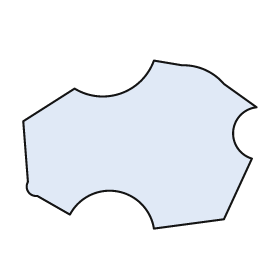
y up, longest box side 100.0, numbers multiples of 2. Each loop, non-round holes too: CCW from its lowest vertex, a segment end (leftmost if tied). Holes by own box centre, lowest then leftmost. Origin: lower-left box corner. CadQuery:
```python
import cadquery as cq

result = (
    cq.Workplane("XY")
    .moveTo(56.0, 0.0)
    .lineTo(86.0, 4.0)
    .lineTo(98.0, 30.0)
    .threePointArc((90.0, 42.0), (100.0, 52.0))
    .lineTo(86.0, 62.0)
    .threePointArc((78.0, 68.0), (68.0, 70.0))
    .lineTo(56.0, 72.0)
    .threePointArc((42.0, 58.0), (22.0, 60.0))
    .lineTo(0.0, 46.0)
    .lineTo(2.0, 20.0)
    .threePointArc((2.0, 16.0), (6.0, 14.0))
    .lineTo(20.0, 6.0)
    .threePointArc((40.0, 16.0), (56.0, 0.0))
    .close()
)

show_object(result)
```